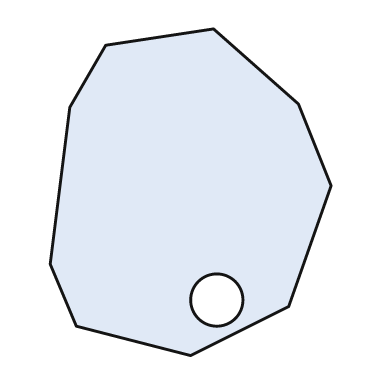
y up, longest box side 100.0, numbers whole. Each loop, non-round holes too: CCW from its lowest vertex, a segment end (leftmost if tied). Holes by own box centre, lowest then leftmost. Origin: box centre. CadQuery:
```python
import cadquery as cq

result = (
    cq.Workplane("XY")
    .moveTo(0.0, -50.0)
    .lineTo(30.0, -35.0)
    .lineTo(43.0, 2.0)
    .lineTo(33.0, 27.0)
    .lineTo(7.0, 50.0)
    .lineTo(-26.0, 45.0)
    .lineTo(-37.0, 26.0)
    .lineTo(-43.0, -22.0)
    .lineTo(-35.0, -41.0)
    .close()
    .moveTo(8.0, -33.0)
    .circle(8.0)
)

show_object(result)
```